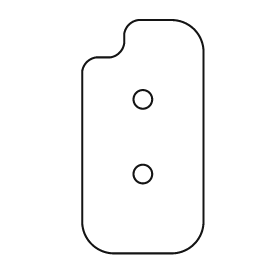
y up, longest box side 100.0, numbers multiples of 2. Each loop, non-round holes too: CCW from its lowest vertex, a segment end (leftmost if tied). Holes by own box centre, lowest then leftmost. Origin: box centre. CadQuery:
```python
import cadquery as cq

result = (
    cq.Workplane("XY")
    .moveTo(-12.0, -50.0)
    .lineTo(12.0, -50.0)
    .threePointArc((22.0, -46.0), (26.0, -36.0))
    .lineTo(26.0, 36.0)
    .threePointArc((22.0, 46.0), (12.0, 50.0))
    .lineTo(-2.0, 50.0)
    .threePointArc((-6.0, 48.0), (-8.0, 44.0))
    .lineTo(-8.0, 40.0)
    .threePointArc((-10.0, 36.0), (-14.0, 34.0))
    .lineTo(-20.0, 34.0)
    .threePointArc((-24.0, 32.0), (-26.0, 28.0))
    .lineTo(-26.0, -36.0)
    .threePointArc((-22.0, -46.0), (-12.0, -50.0))
    .close()
    .moveTo(0.0, -16.0)
    .circle(4.0)
    .moveTo(0.0, 16.0)
    .circle(4.0)
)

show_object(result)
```